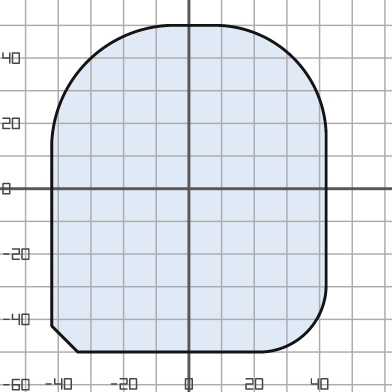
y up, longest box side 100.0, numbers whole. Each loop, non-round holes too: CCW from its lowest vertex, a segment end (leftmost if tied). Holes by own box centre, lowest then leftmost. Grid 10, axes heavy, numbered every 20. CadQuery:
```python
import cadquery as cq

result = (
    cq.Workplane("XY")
    .moveTo(-34.0, -50.0)
    .lineTo(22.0, -50.0)
    .threePointArc((36.0, -44.0), (42.0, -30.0))
    .lineTo(42.0, 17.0)
    .threePointArc((32.0, 40.0), (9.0, 50.0))
    .lineTo(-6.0, 50.0)
    .threePointArc((-31.0, 39.0), (-42.0, 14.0))
    .lineTo(-42.0, -42.0)
    .close()
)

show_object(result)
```